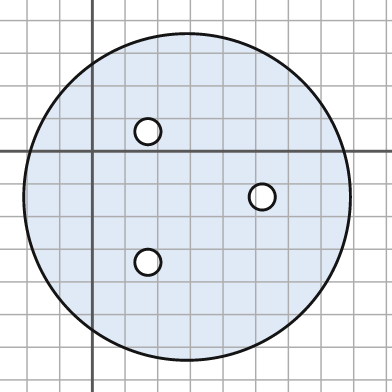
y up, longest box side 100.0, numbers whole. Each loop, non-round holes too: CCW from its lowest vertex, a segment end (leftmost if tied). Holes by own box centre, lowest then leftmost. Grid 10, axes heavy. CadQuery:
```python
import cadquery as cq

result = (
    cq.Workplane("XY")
    .moveTo(29.0, -14.0)
    .circle(50.0)
    .moveTo(17.0, -34.0)
    .circle(4.0)
    .moveTo(52.0, -14.0)
    .circle(4.0)
    .moveTo(17.0, 6.0)
    .circle(4.0)
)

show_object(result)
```